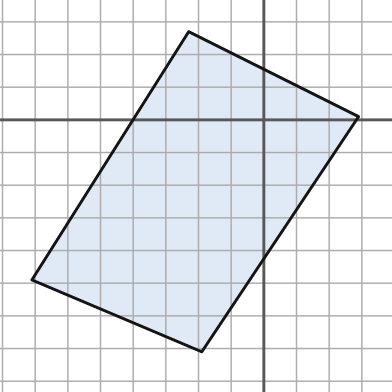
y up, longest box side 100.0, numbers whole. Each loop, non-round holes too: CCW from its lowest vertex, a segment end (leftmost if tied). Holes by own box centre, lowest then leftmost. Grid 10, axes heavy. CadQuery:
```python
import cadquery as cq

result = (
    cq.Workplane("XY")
    .moveTo(-19.0, -71.0)
    .lineTo(29.0, 1.0)
    .lineTo(-23.0, 27.0)
    .lineTo(-71.0, -49.0)
    .close()
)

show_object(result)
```